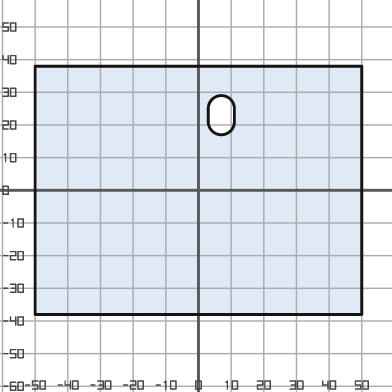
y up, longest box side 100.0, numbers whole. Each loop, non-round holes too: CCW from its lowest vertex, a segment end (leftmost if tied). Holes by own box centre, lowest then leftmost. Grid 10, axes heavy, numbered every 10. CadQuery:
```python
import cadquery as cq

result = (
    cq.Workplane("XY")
    .moveTo(-50.0, -38.0)
    .lineTo(50.0, -38.0)
    .lineTo(50.0, 38.0)
    .lineTo(-50.0, 38.0)
    .close()
    .moveTo(3.0, 21.0)
    .threePointArc((7.0, 17.0), (11.0, 21.0))
    .lineTo(11.0, 25.0)
    .threePointArc((7.0, 29.0), (3.0, 25.0))
    .close()
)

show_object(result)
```